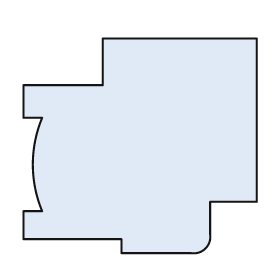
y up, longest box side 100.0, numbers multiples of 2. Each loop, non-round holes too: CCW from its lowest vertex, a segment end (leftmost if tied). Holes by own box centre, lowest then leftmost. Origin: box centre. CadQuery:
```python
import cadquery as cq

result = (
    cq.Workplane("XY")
    .moveTo(-8.0, -46.0)
    .lineTo(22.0, -46.0)
    .threePointArc((28.0, -44.0), (30.0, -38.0))
    .lineTo(30.0, -24.0)
    .lineTo(50.0, -24.0)
    .lineTo(50.0, 46.0)
    .lineTo(-16.0, 46.0)
    .lineTo(-16.0, 26.0)
    .lineTo(-50.0, 26.0)
    .lineTo(-50.0, 12.0)
    .lineTo(-42.0, 12.0)
    .threePointArc((-46.0, -8.0), (-42.0, -28.0))
    .lineTo(-50.0, -28.0)
    .lineTo(-50.0, -40.0)
    .lineTo(-8.0, -40.0)
    .close()
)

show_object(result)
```